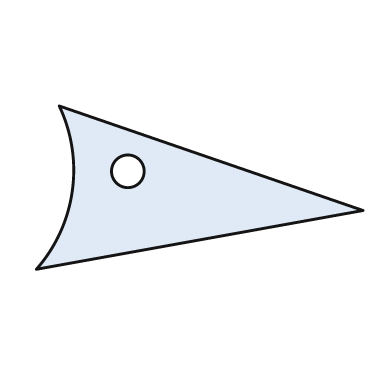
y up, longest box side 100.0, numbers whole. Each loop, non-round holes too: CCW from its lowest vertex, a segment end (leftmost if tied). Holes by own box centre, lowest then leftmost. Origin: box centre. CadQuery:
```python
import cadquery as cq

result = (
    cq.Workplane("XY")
    .moveTo(-50.0, -25.0)
    .lineTo(50.0, -7.0)
    .lineTo(-43.0, 25.0)
    .threePointArc((-39.0, -1.0), (-50.0, -25.0))
    .close()
    .moveTo(-22.0, 5.0)
    .circle(5.0)
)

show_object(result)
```